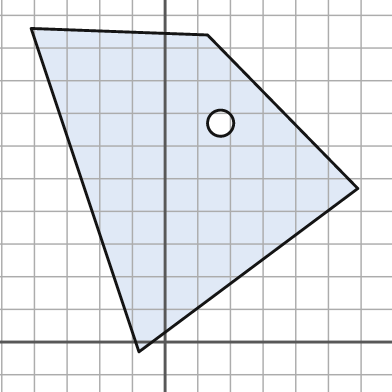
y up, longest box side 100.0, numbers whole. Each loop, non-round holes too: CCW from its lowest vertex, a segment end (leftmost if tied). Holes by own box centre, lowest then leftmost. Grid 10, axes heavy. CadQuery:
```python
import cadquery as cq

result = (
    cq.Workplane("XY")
    .moveTo(-8.0, -3.0)
    .lineTo(59.0, 47.0)
    .lineTo(13.0, 94.0)
    .lineTo(-41.0, 96.0)
    .close()
    .moveTo(17.0, 67.0)
    .circle(4.0)
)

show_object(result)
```